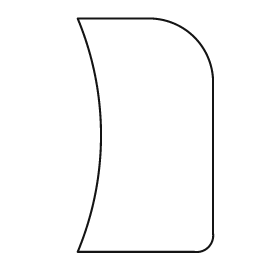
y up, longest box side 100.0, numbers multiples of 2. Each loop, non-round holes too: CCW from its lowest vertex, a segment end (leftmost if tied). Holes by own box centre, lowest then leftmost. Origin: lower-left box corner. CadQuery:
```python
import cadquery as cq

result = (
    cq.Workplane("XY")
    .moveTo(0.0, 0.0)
    .lineTo(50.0, 0.0)
    .threePointArc((56.0, 2.0), (58.0, 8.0))
    .lineTo(58.0, 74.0)
    .threePointArc((50.0, 92.0), (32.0, 100.0))
    .lineTo(0.0, 100.0)
    .threePointArc((10.0, 50.0), (0.0, 0.0))
    .close()
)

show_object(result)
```